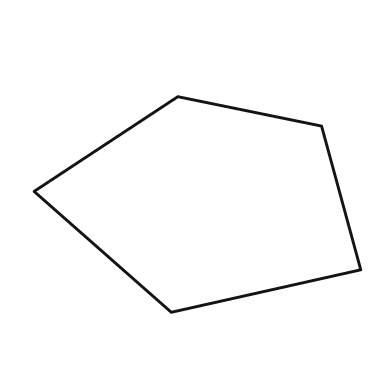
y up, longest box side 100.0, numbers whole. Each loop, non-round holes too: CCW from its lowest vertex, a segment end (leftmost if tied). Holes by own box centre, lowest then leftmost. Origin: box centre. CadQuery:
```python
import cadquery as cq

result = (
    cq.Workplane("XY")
    .moveTo(-8.0, -33.0)
    .lineTo(50.0, -20.0)
    .lineTo(38.0, 24.0)
    .lineTo(-6.0, 33.0)
    .lineTo(-50.0, 4.0)
    .close()
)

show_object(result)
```